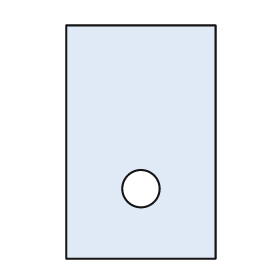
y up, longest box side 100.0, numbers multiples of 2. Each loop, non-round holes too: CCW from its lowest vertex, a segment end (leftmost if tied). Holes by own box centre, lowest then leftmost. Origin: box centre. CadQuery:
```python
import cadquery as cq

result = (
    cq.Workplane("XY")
    .moveTo(-32.0, -50.0)
    .lineTo(32.0, -50.0)
    .lineTo(32.0, 50.0)
    .lineTo(-32.0, 50.0)
    .close()
    .moveTo(0.0, -20.0)
    .circle(8.0)
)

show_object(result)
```